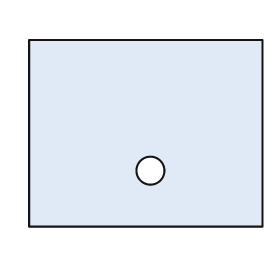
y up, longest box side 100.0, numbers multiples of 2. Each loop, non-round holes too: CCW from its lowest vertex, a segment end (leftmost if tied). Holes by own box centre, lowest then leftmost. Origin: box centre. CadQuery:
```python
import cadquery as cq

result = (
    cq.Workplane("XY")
    .moveTo(-50.0, -40.0)
    .lineTo(50.0, -40.0)
    .lineTo(50.0, 40.0)
    .lineTo(-50.0, 40.0)
    .close()
    .moveTo(2.0, -16.0)
    .circle(6.0)
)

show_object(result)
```